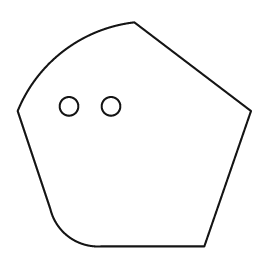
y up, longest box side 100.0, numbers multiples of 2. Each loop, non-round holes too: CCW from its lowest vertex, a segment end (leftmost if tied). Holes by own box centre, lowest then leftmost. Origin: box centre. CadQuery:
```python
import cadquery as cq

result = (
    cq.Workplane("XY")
    .moveTo(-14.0, -48.0)
    .lineTo(30.0, -48.0)
    .lineTo(50.0, 10.0)
    .lineTo(0.0, 48.0)
    .threePointArc((-30.0, 36.0), (-50.0, 10.0))
    .lineTo(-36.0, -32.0)
    .threePointArc((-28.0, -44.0), (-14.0, -48.0))
    .close()
    .moveTo(-28.0, 12.0)
    .circle(4.0)
    .moveTo(-10.0, 12.0)
    .circle(4.0)
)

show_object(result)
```